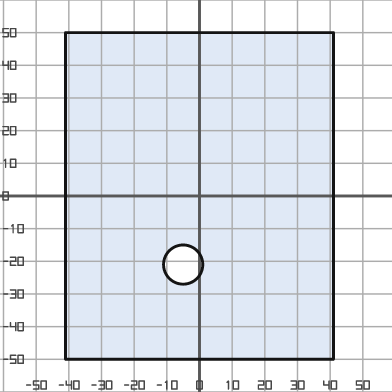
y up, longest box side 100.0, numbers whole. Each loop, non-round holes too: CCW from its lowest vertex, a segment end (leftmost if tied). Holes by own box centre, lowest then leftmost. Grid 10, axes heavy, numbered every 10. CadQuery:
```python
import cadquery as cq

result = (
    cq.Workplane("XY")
    .moveTo(-41.0, -50.0)
    .lineTo(41.0, -50.0)
    .lineTo(41.0, 50.0)
    .lineTo(-41.0, 50.0)
    .close()
    .moveTo(-5.0, -21.0)
    .circle(6.0)
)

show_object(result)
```